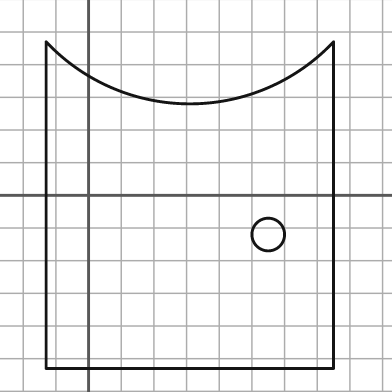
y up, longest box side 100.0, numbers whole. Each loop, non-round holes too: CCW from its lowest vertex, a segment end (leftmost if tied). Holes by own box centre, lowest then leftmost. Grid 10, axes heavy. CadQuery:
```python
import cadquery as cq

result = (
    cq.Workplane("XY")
    .moveTo(-13.0, -53.0)
    .lineTo(75.0, -53.0)
    .lineTo(75.0, 47.0)
    .threePointArc((31.0, 28.0), (-13.0, 47.0))
    .close()
    .moveTo(55.0, -12.0)
    .circle(5.0)
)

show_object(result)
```